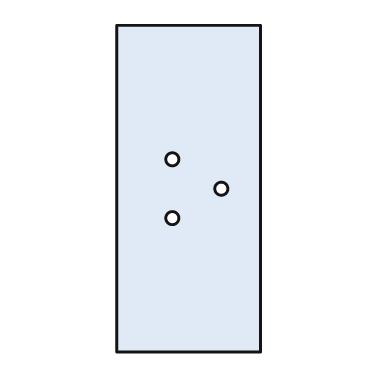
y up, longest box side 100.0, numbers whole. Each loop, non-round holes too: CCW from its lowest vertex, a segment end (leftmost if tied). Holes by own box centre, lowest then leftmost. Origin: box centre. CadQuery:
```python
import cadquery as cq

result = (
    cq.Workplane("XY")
    .moveTo(-22.0, -50.0)
    .lineTo(22.0, -50.0)
    .lineTo(22.0, 50.0)
    .lineTo(-22.0, 50.0)
    .close()
    .moveTo(-5.0, -9.0)
    .circle(2.0)
    .moveTo(10.0, 0.0)
    .circle(2.0)
    .moveTo(-5.0, 9.0)
    .circle(2.0)
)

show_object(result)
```